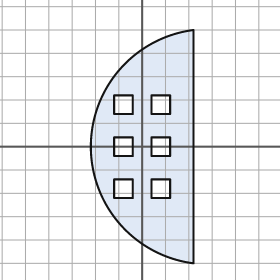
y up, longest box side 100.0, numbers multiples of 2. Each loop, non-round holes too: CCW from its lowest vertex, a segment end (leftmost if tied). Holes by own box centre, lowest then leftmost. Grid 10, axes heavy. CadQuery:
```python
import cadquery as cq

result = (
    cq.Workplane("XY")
    .moveTo(22.0, -50.0)
    .lineTo(22.0, 50.0)
    .threePointArc((-22.0, 0.0), (22.0, -50.0))
    .close()
    .moveTo(-12.0, -22.0)
    .lineTo(-4.0, -22.0)
    .lineTo(-4.0, -14.0)
    .lineTo(-12.0, -14.0)
    .close()
    .moveTo(4.0, -22.0)
    .lineTo(12.0, -22.0)
    .lineTo(12.0, -14.0)
    .lineTo(4.0, -14.0)
    .close()
    .moveTo(-12.0, -4.0)
    .lineTo(-4.0, -4.0)
    .lineTo(-4.0, 4.0)
    .lineTo(-12.0, 4.0)
    .close()
    .moveTo(4.0, -4.0)
    .lineTo(12.0, -4.0)
    .lineTo(12.0, 4.0)
    .lineTo(4.0, 4.0)
    .close()
    .moveTo(-12.0, 14.0)
    .lineTo(-4.0, 14.0)
    .lineTo(-4.0, 22.0)
    .lineTo(-12.0, 22.0)
    .close()
    .moveTo(4.0, 14.0)
    .lineTo(12.0, 14.0)
    .lineTo(12.0, 22.0)
    .lineTo(4.0, 22.0)
    .close()
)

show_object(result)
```